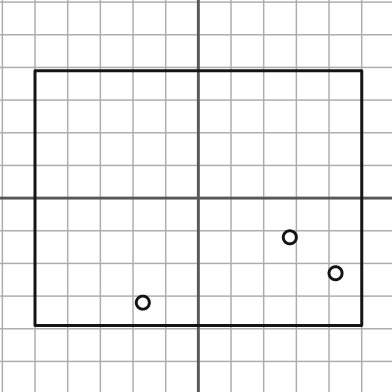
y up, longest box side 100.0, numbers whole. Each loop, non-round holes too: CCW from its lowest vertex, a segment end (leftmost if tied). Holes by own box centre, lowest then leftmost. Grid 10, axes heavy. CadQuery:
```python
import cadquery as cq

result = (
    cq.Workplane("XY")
    .moveTo(-50.0, -39.0)
    .lineTo(50.0, -39.0)
    .lineTo(50.0, 39.0)
    .lineTo(-50.0, 39.0)
    .close()
    .moveTo(-17.0, -32.0)
    .circle(2.0)
    .moveTo(42.0, -23.0)
    .circle(2.0)
    .moveTo(28.0, -12.0)
    .circle(2.0)
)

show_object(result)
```